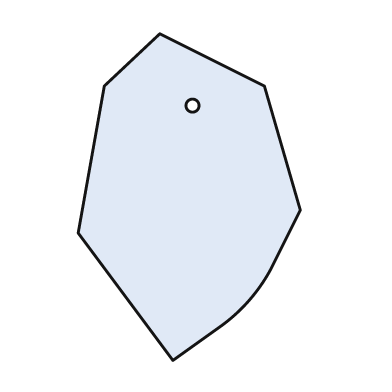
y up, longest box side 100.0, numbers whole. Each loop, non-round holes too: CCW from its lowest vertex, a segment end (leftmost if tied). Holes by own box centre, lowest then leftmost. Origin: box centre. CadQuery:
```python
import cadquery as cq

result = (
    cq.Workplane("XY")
    .moveTo(-5.0, -50.0)
    .lineTo(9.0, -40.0)
    .threePointArc((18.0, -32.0), (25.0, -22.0))
    .lineTo(34.0, -4.0)
    .lineTo(23.0, 34.0)
    .lineTo(-9.0, 50.0)
    .lineTo(-26.0, 34.0)
    .lineTo(-34.0, -11.0)
    .close()
    .moveTo(1.0, 28.0)
    .circle(2.0)
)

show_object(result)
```